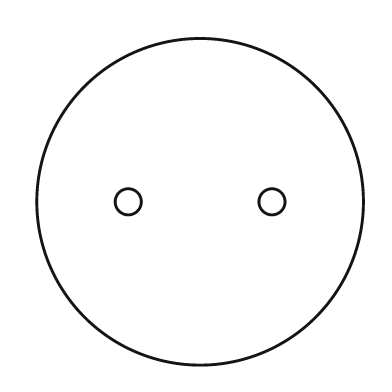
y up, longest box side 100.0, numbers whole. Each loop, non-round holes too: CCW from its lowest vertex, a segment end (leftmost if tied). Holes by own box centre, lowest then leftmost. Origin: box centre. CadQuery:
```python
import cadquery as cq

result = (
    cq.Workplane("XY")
    .moveTo(0.0, 0.0)
    .circle(50.0)
    .moveTo(-22.0, 0.0)
    .circle(4.0)
    .moveTo(22.0, 0.0)
    .circle(4.0)
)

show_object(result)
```